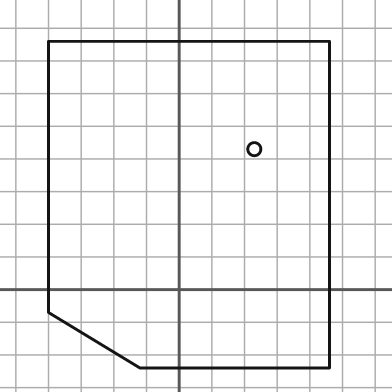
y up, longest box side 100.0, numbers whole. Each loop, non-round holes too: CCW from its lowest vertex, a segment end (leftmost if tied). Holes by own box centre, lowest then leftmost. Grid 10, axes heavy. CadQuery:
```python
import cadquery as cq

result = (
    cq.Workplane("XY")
    .moveTo(-12.0, -24.0)
    .lineTo(46.0, -24.0)
    .lineTo(46.0, 76.0)
    .lineTo(-40.0, 76.0)
    .lineTo(-40.0, -7.0)
    .close()
    .moveTo(23.0, 43.0)
    .circle(2.0)
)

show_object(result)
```